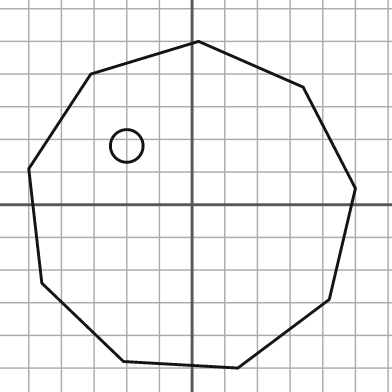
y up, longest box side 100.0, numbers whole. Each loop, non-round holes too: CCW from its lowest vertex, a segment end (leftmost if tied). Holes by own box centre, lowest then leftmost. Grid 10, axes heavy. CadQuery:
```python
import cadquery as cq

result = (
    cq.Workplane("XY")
    .moveTo(14.0, -50.0)
    .lineTo(42.0, -29.0)
    .lineTo(50.0, 5.0)
    .lineTo(34.0, 36.0)
    .lineTo(2.0, 50.0)
    .lineTo(-31.0, 40.0)
    .lineTo(-50.0, 11.0)
    .lineTo(-46.0, -24.0)
    .lineTo(-21.0, -48.0)
    .close()
    .moveTo(-20.0, 18.0)
    .circle(5.0)
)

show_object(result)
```